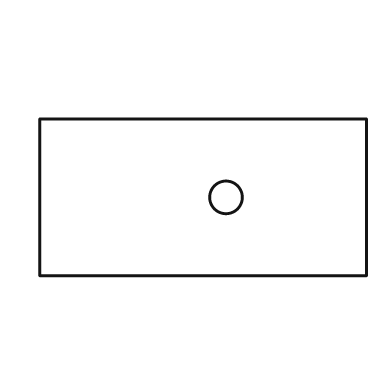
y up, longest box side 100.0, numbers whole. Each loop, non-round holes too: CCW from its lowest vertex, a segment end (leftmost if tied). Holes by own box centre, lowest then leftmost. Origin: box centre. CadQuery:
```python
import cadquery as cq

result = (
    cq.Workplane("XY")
    .moveTo(-50.0, -24.0)
    .lineTo(50.0, -24.0)
    .lineTo(50.0, 24.0)
    .lineTo(-50.0, 24.0)
    .close()
    .moveTo(7.0, 0.0)
    .circle(5.0)
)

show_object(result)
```